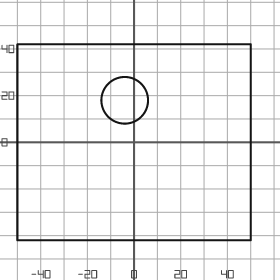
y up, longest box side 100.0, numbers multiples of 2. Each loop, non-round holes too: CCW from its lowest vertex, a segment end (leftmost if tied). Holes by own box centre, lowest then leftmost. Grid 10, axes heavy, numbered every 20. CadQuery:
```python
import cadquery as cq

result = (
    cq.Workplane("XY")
    .moveTo(-50.0, -42.0)
    .lineTo(50.0, -42.0)
    .lineTo(50.0, 42.0)
    .lineTo(-50.0, 42.0)
    .close()
    .moveTo(-4.0, 18.0)
    .circle(10.0)
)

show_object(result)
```